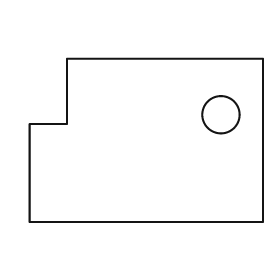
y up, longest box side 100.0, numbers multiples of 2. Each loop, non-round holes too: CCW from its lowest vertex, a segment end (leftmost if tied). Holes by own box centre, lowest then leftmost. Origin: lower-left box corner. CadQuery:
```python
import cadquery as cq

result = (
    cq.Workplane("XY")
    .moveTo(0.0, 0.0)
    .lineTo(100.0, 0.0)
    .lineTo(100.0, 70.0)
    .lineTo(16.0, 70.0)
    .lineTo(16.0, 42.0)
    .lineTo(0.0, 42.0)
    .close()
    .moveTo(82.0, 46.0)
    .circle(8.0)
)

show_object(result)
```